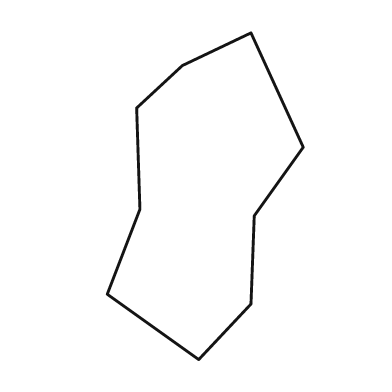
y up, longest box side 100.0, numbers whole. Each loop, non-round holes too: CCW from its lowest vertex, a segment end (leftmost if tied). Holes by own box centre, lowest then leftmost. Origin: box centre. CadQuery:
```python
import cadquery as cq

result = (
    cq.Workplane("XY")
    .moveTo(-2.0, -50.0)
    .lineTo(14.0, -33.0)
    .lineTo(15.0, -6.0)
    .lineTo(30.0, 15.0)
    .lineTo(14.0, 50.0)
    .lineTo(-7.0, 40.0)
    .lineTo(-21.0, 27.0)
    .lineTo(-20.0, -4.0)
    .lineTo(-30.0, -30.0)
    .close()
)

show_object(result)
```